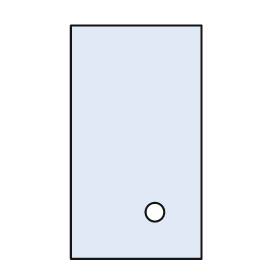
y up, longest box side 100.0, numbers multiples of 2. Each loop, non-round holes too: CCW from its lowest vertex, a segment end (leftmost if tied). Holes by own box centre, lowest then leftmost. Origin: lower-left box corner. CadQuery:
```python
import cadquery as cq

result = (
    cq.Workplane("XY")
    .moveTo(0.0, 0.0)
    .lineTo(56.0, 0.0)
    .lineTo(56.0, 100.0)
    .lineTo(0.0, 100.0)
    .close()
    .moveTo(36.0, 20.0)
    .circle(4.0)
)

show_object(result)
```